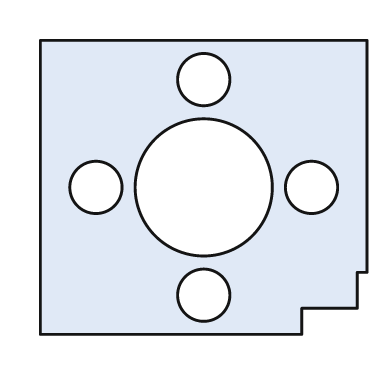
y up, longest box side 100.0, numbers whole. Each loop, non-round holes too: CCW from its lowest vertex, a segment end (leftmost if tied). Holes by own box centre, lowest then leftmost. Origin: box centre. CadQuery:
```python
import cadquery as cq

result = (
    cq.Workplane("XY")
    .moveTo(-50.0, -45.0)
    .lineTo(30.0, -45.0)
    .lineTo(30.0, -37.0)
    .lineTo(47.0, -37.0)
    .lineTo(47.0, -26.0)
    .lineTo(50.0, -26.0)
    .lineTo(50.0, 45.0)
    .lineTo(-50.0, 45.0)
    .close()
    .moveTo(0.0, -33.0)
    .circle(8.0)
    .moveTo(-33.0, 0.0)
    .circle(8.0)
    .moveTo(0.0, 0.0)
    .circle(21.0)
    .moveTo(33.0, 0.0)
    .circle(8.0)
    .moveTo(0.0, 33.0)
    .circle(8.0)
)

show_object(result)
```